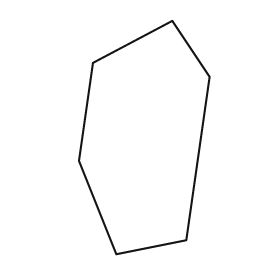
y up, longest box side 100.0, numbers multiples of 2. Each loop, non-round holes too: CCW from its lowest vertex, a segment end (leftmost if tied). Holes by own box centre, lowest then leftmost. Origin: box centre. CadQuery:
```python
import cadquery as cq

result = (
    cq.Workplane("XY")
    .moveTo(-12.0, -50.0)
    .lineTo(18.0, -44.0)
    .lineTo(28.0, 26.0)
    .lineTo(12.0, 50.0)
    .lineTo(-22.0, 32.0)
    .lineTo(-28.0, -10.0)
    .close()
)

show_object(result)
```